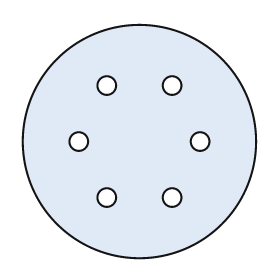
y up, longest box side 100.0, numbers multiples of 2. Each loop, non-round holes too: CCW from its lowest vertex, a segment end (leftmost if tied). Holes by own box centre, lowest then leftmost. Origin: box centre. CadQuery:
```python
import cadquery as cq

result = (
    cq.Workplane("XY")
    .moveTo(0.0, 0.0)
    .circle(50.0)
    .moveTo(-14.0, -24.0)
    .circle(4.0)
    .moveTo(14.0, -24.0)
    .circle(4.0)
    .moveTo(-26.0, 0.0)
    .circle(4.0)
    .moveTo(26.0, 0.0)
    .circle(4.0)
    .moveTo(-14.0, 24.0)
    .circle(4.0)
    .moveTo(14.0, 24.0)
    .circle(4.0)
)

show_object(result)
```